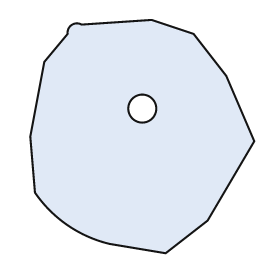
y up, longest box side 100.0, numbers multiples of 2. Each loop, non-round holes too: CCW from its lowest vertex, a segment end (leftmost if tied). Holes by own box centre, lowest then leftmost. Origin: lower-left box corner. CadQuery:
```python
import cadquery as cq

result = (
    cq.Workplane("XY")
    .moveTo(58.0, 0.0)
    .lineTo(76.0, 14.0)
    .lineTo(96.0, 48.0)
    .lineTo(84.0, 76.0)
    .lineTo(70.0, 94.0)
    .lineTo(52.0, 100.0)
    .lineTo(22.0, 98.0)
    .threePointArc((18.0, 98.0), (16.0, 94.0))
    .lineTo(6.0, 82.0)
    .lineTo(0.0, 50.0)
    .lineTo(2.0, 26.0)
    .threePointArc((16.0, 12.0), (34.0, 4.0))
    .close()
    .moveTo(48.0, 62.0)
    .circle(6.0)
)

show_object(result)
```